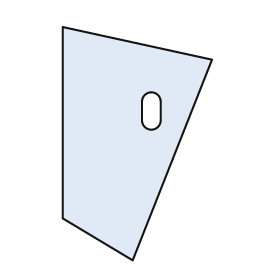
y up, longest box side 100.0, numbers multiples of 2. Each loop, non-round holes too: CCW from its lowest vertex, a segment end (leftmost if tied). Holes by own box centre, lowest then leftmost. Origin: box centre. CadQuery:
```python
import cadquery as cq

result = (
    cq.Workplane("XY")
    .moveTo(-2.0, -50.0)
    .lineTo(32.0, 36.0)
    .lineTo(-32.0, 50.0)
    .lineTo(-32.0, -32.0)
    .close()
    .moveTo(2.0, 10.0)
    .threePointArc((6.0, 6.0), (10.0, 10.0))
    .lineTo(10.0, 18.0)
    .threePointArc((6.0, 22.0), (2.0, 18.0))
    .close()
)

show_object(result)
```